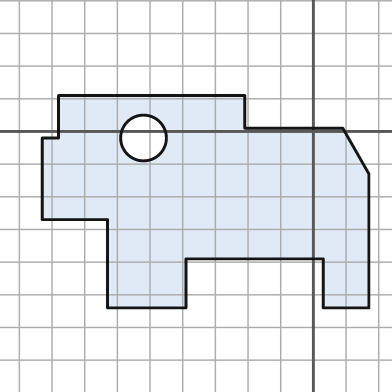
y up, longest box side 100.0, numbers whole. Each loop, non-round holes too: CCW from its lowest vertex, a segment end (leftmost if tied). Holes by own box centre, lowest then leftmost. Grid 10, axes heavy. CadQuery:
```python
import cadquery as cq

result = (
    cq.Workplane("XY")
    .moveTo(-63.0, -54.0)
    .lineTo(-39.0, -54.0)
    .lineTo(-39.0, -39.0)
    .lineTo(3.0, -39.0)
    .lineTo(3.0, -54.0)
    .lineTo(17.0, -54.0)
    .lineTo(17.0, -13.0)
    .lineTo(9.0, 1.0)
    .lineTo(-21.0, 1.0)
    .lineTo(-21.0, 11.0)
    .lineTo(-78.0, 11.0)
    .lineTo(-78.0, -2.0)
    .lineTo(-83.0, -2.0)
    .lineTo(-83.0, -27.0)
    .lineTo(-63.0, -27.0)
    .close()
    .moveTo(-52.0, -2.0)
    .circle(7.0)
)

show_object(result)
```